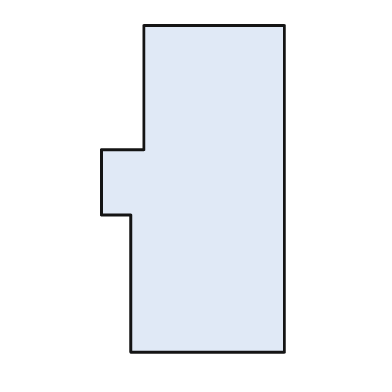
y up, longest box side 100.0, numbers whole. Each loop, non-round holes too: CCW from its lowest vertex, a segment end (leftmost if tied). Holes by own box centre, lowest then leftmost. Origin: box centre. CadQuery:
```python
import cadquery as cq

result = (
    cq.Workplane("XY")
    .moveTo(-19.0, -50.0)
    .lineTo(28.0, -50.0)
    .lineTo(28.0, 50.0)
    .lineTo(-15.0, 50.0)
    .lineTo(-15.0, 12.0)
    .lineTo(-28.0, 12.0)
    .lineTo(-28.0, -8.0)
    .lineTo(-19.0, -8.0)
    .close()
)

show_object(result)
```